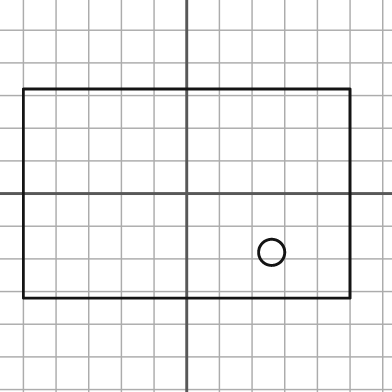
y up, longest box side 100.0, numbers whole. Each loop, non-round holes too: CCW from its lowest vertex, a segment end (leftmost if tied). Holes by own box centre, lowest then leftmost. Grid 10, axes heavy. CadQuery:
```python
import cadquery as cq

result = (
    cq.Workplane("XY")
    .moveTo(-50.0, -32.0)
    .lineTo(50.0, -32.0)
    .lineTo(50.0, 32.0)
    .lineTo(-50.0, 32.0)
    .close()
    .moveTo(26.0, -18.0)
    .circle(4.0)
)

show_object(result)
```